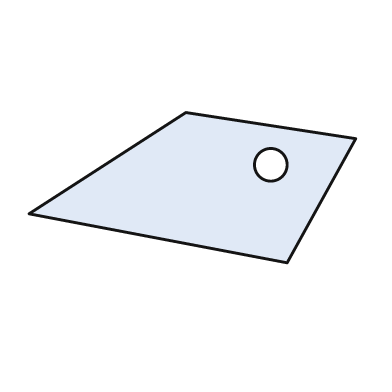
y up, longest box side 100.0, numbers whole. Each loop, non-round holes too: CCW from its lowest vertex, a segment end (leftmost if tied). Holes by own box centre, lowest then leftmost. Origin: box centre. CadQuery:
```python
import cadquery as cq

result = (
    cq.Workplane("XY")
    .moveTo(29.0, -23.0)
    .lineTo(50.0, 15.0)
    .lineTo(-2.0, 23.0)
    .lineTo(-50.0, -8.0)
    .close()
    .moveTo(24.0, 7.0)
    .circle(5.0)
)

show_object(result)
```